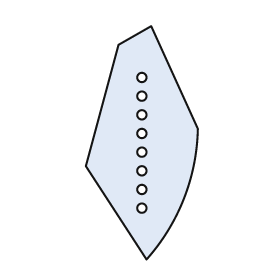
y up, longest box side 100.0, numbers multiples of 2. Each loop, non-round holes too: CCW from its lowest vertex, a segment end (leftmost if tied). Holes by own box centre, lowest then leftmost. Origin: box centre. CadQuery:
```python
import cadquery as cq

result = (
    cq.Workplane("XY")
    .moveTo(2.0, -50.0)
    .threePointArc((18.0, -24.0), (24.0, 6.0))
    .lineTo(4.0, 50.0)
    .lineTo(-10.0, 42.0)
    .lineTo(-24.0, -10.0)
    .close()
    .moveTo(0.0, -28.0)
    .circle(2.0)
    .moveTo(0.0, -20.0)
    .circle(2.0)
    .moveTo(0.0, -12.0)
    .circle(2.0)
    .moveTo(0.0, -4.0)
    .circle(2.0)
    .moveTo(0.0, 4.0)
    .circle(2.0)
    .moveTo(0.0, 12.0)
    .circle(2.0)
    .moveTo(0.0, 20.0)
    .circle(2.0)
    .moveTo(0.0, 28.0)
    .circle(2.0)
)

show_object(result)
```